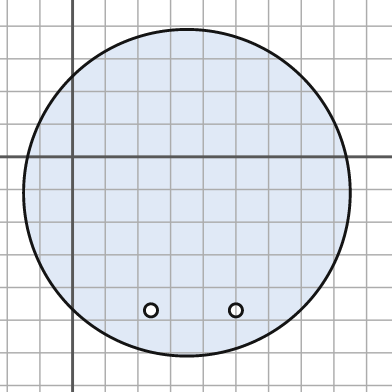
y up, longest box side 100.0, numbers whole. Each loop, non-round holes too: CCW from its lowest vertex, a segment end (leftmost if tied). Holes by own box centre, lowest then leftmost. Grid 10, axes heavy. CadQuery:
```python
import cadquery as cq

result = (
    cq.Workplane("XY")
    .moveTo(35.0, -11.0)
    .circle(50.0)
    .moveTo(24.0, -47.0)
    .circle(2.0)
    .moveTo(50.0, -47.0)
    .circle(2.0)
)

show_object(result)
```